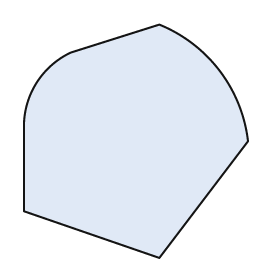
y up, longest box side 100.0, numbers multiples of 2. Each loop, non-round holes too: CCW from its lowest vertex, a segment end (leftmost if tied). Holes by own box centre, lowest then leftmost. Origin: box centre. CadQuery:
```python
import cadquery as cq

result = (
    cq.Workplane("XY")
    .moveTo(10.0, -50.0)
    .lineTo(48.0, 0.0)
    .threePointArc((36.0, 30.0), (10.0, 50.0))
    .lineTo(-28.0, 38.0)
    .threePointArc((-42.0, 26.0), (-48.0, 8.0))
    .lineTo(-48.0, -30.0)
    .close()
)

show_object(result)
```